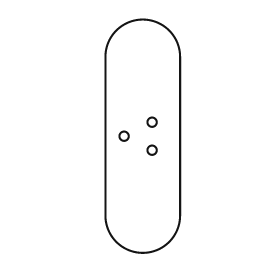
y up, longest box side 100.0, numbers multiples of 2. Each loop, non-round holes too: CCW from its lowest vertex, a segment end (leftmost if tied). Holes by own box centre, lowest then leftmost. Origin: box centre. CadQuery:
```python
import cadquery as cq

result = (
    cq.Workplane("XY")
    .moveTo(-16.0, -34.0)
    .threePointArc((0.0, -50.0), (16.0, -34.0))
    .lineTo(16.0, 34.0)
    .threePointArc((0.0, 50.0), (-16.0, 34.0))
    .close()
    .moveTo(4.0, -6.0)
    .circle(2.0)
    .moveTo(-8.0, 0.0)
    .circle(2.0)
    .moveTo(4.0, 6.0)
    .circle(2.0)
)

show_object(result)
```